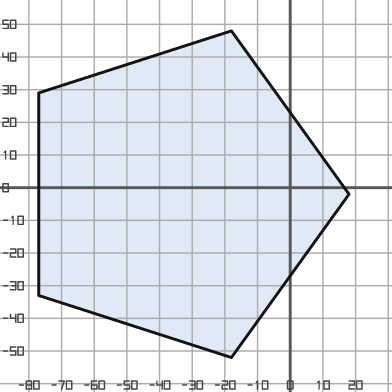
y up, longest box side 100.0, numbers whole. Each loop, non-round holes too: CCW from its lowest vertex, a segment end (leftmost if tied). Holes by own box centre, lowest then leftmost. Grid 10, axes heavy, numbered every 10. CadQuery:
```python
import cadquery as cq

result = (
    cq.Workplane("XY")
    .moveTo(-18.0, -52.0)
    .lineTo(18.0, -2.0)
    .lineTo(-18.0, 48.0)
    .lineTo(-77.0, 29.0)
    .lineTo(-77.0, -33.0)
    .close()
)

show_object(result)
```